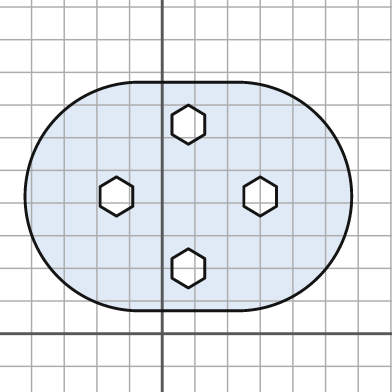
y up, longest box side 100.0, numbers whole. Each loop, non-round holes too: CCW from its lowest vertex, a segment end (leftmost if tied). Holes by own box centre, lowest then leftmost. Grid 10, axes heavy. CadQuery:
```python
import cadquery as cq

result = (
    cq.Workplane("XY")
    .moveTo(-7.0, 7.0)
    .lineTo(23.0, 7.0)
    .threePointArc((58.0, 42.0), (23.0, 77.0))
    .lineTo(-7.0, 77.0)
    .threePointArc((-42.0, 42.0), (-7.0, 7.0))
    .close()
    .moveTo(8.0, 14.0)
    .lineTo(13.0, 17.0)
    .lineTo(13.0, 23.0)
    .lineTo(8.0, 26.0)
    .lineTo(3.0, 23.0)
    .lineTo(3.0, 17.0)
    .close()
    .moveTo(-14.0, 36.0)
    .lineTo(-9.0, 39.0)
    .lineTo(-9.0, 45.0)
    .lineTo(-14.0, 48.0)
    .lineTo(-19.0, 45.0)
    .lineTo(-19.0, 39.0)
    .close()
    .moveTo(30.0, 36.0)
    .lineTo(35.0, 39.0)
    .lineTo(35.0, 45.0)
    .lineTo(30.0, 48.0)
    .lineTo(25.0, 45.0)
    .lineTo(25.0, 39.0)
    .close()
    .moveTo(8.0, 58.0)
    .lineTo(13.0, 61.0)
    .lineTo(13.0, 67.0)
    .lineTo(8.0, 70.0)
    .lineTo(3.0, 67.0)
    .lineTo(3.0, 61.0)
    .close()
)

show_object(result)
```